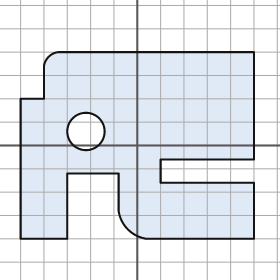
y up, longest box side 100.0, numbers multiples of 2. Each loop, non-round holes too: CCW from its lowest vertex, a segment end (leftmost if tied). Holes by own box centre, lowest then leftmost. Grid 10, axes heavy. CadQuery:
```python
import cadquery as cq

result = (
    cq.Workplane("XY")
    .moveTo(-50.0, -40.0)
    .lineTo(-30.0, -40.0)
    .lineTo(-30.0, -12.0)
    .lineTo(-8.0, -12.0)
    .lineTo(-8.0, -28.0)
    .threePointArc((-4.0, -36.0), (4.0, -40.0))
    .lineTo(50.0, -40.0)
    .lineTo(50.0, -16.0)
    .lineTo(10.0, -16.0)
    .lineTo(10.0, -6.0)
    .lineTo(50.0, -6.0)
    .lineTo(50.0, 40.0)
    .lineTo(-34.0, 40.0)
    .threePointArc((-38.0, 38.0), (-40.0, 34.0))
    .lineTo(-40.0, 20.0)
    .lineTo(-50.0, 20.0)
    .close()
    .moveTo(-22.0, 6.0)
    .circle(8.0)
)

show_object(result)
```